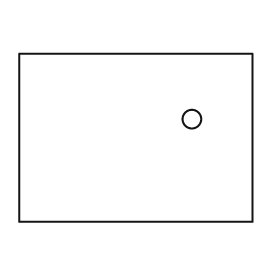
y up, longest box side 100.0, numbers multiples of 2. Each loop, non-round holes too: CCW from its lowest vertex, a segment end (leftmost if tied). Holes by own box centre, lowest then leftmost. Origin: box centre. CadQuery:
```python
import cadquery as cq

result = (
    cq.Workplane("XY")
    .moveTo(-50.0, -36.0)
    .lineTo(50.0, -36.0)
    .lineTo(50.0, 36.0)
    .lineTo(-50.0, 36.0)
    .close()
    .moveTo(24.0, 8.0)
    .circle(4.0)
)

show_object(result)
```